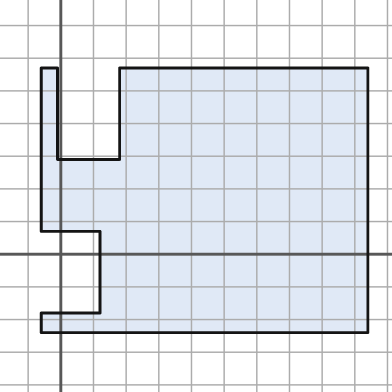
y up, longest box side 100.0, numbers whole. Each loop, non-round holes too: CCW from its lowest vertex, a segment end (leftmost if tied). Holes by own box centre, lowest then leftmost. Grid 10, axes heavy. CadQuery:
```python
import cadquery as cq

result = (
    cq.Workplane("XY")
    .moveTo(-6.0, -24.0)
    .lineTo(94.0, -24.0)
    .lineTo(94.0, 57.0)
    .lineTo(18.0, 57.0)
    .lineTo(18.0, 29.0)
    .lineTo(-1.0, 29.0)
    .lineTo(-1.0, 57.0)
    .lineTo(-6.0, 57.0)
    .lineTo(-6.0, 7.0)
    .lineTo(12.0, 7.0)
    .lineTo(12.0, -18.0)
    .lineTo(-6.0, -18.0)
    .close()
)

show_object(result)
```